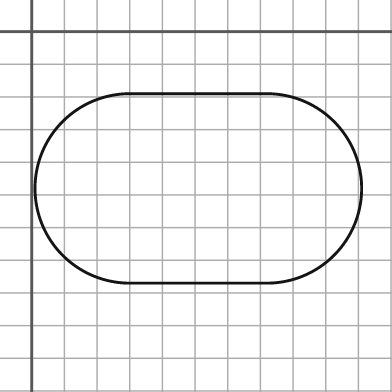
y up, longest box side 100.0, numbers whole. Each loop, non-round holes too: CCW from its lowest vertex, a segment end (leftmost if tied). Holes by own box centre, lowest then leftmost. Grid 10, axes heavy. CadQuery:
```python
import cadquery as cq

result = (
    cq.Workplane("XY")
    .moveTo(30.0, -77.0)
    .lineTo(72.0, -77.0)
    .threePointArc((101.0, -48.0), (72.0, -19.0))
    .lineTo(30.0, -19.0)
    .threePointArc((1.0, -48.0), (30.0, -77.0))
    .close()
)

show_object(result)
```